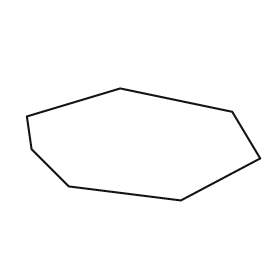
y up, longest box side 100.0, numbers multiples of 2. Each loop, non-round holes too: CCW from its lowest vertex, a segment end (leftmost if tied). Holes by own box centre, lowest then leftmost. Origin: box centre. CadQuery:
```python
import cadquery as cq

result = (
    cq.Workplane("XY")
    .moveTo(16.0, -24.0)
    .lineTo(50.0, -6.0)
    .lineTo(38.0, 14.0)
    .lineTo(-10.0, 24.0)
    .lineTo(-50.0, 12.0)
    .lineTo(-48.0, -2.0)
    .lineTo(-32.0, -18.0)
    .close()
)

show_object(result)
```